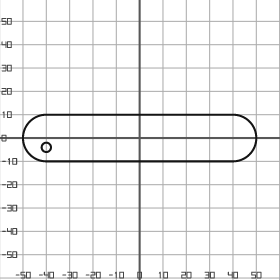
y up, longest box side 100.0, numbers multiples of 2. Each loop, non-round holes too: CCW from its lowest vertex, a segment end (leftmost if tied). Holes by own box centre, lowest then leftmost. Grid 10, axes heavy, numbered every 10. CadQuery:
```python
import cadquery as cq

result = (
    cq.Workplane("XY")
    .moveTo(-40.0, -10.0)
    .lineTo(40.0, -10.0)
    .threePointArc((50.0, 0.0), (40.0, 10.0))
    .lineTo(-40.0, 10.0)
    .threePointArc((-50.0, 0.0), (-40.0, -10.0))
    .close()
    .moveTo(-40.0, -4.0)
    .circle(2.0)
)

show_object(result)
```